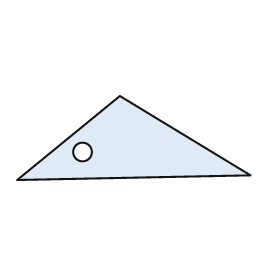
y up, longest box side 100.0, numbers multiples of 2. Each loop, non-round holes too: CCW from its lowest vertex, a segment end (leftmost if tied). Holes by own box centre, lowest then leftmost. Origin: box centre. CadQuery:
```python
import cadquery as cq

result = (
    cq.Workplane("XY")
    .moveTo(-50.0, -18.0)
    .lineTo(50.0, -16.0)
    .lineTo(-6.0, 18.0)
    .close()
    .moveTo(-22.0, -6.0)
    .circle(4.0)
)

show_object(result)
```